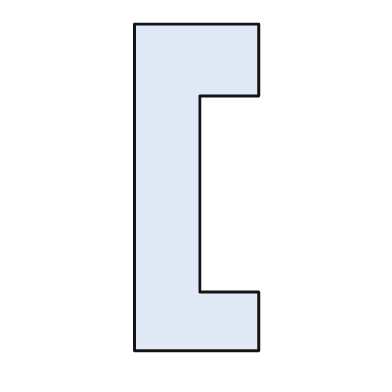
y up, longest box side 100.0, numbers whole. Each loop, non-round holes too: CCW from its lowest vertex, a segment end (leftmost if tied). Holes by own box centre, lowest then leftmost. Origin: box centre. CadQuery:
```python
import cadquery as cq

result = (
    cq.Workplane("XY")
    .moveTo(-19.0, -50.0)
    .lineTo(19.0, -50.0)
    .lineTo(19.0, -32.0)
    .lineTo(1.0, -32.0)
    .lineTo(1.0, 28.0)
    .lineTo(19.0, 28.0)
    .lineTo(19.0, 50.0)
    .lineTo(-19.0, 50.0)
    .close()
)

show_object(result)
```